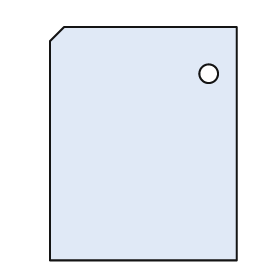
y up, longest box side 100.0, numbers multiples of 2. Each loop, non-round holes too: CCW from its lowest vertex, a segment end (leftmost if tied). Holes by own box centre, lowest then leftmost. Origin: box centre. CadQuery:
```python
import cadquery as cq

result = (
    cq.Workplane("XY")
    .moveTo(-40.0, -50.0)
    .lineTo(40.0, -50.0)
    .lineTo(40.0, 50.0)
    .lineTo(-34.0, 50.0)
    .lineTo(-40.0, 44.0)
    .close()
    .moveTo(28.0, 30.0)
    .circle(4.0)
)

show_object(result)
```